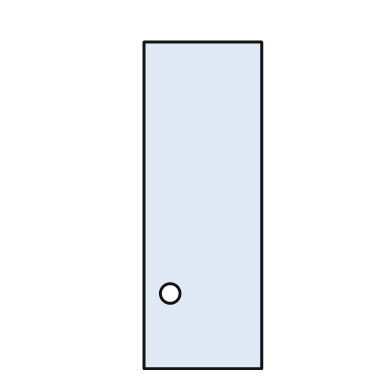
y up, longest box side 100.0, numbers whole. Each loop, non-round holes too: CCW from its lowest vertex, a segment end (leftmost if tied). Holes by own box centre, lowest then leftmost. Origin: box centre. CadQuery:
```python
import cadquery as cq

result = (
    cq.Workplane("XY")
    .moveTo(-18.0, -50.0)
    .lineTo(18.0, -50.0)
    .lineTo(18.0, 50.0)
    .lineTo(-18.0, 50.0)
    .close()
    .moveTo(-10.0, -27.0)
    .circle(3.0)
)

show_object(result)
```